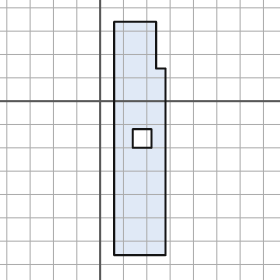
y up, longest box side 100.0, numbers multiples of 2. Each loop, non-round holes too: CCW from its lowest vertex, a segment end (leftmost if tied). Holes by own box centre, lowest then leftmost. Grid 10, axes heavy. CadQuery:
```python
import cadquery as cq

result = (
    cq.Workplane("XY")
    .moveTo(6.0, -66.0)
    .lineTo(28.0, -66.0)
    .lineTo(28.0, 14.0)
    .lineTo(24.0, 14.0)
    .lineTo(24.0, 34.0)
    .lineTo(6.0, 34.0)
    .close()
    .moveTo(14.0, -20.0)
    .lineTo(22.0, -20.0)
    .lineTo(22.0, -12.0)
    .lineTo(14.0, -12.0)
    .close()
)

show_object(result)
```